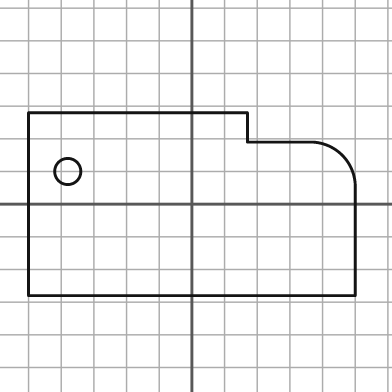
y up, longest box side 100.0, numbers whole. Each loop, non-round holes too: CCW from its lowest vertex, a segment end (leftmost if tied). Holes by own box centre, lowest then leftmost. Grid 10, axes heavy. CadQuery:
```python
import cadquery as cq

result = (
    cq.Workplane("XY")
    .moveTo(-50.0, -28.0)
    .lineTo(50.0, -28.0)
    .lineTo(50.0, 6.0)
    .threePointArc((46.0, 15.0), (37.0, 19.0))
    .lineTo(17.0, 19.0)
    .lineTo(17.0, 28.0)
    .lineTo(-50.0, 28.0)
    .close()
    .moveTo(-38.0, 10.0)
    .circle(4.0)
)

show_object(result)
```